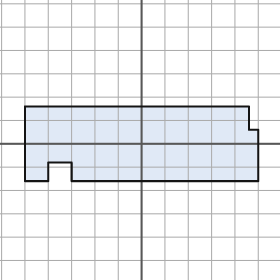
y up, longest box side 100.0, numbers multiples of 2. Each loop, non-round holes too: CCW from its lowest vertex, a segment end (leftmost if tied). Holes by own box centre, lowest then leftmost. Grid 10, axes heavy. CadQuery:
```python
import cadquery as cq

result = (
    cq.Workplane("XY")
    .moveTo(-50.0, -16.0)
    .lineTo(-40.0, -16.0)
    .lineTo(-40.0, -8.0)
    .lineTo(-30.0, -8.0)
    .lineTo(-30.0, -16.0)
    .lineTo(50.0, -16.0)
    .lineTo(50.0, 6.0)
    .lineTo(46.0, 6.0)
    .lineTo(46.0, 16.0)
    .lineTo(-50.0, 16.0)
    .close()
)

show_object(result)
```